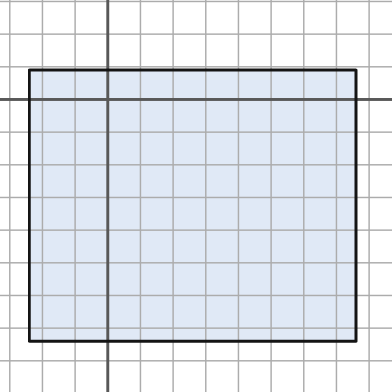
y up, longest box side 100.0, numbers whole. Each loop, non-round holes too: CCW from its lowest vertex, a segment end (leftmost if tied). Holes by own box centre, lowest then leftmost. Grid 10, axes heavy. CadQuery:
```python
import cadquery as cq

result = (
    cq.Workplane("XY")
    .moveTo(-24.0, -74.0)
    .lineTo(76.0, -74.0)
    .lineTo(76.0, 9.0)
    .lineTo(-24.0, 9.0)
    .close()
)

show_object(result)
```